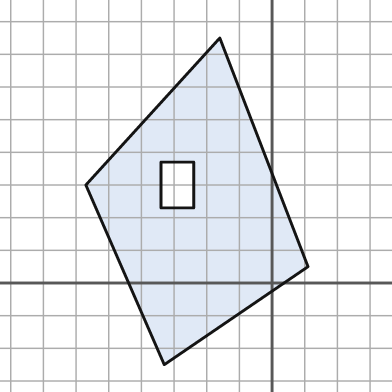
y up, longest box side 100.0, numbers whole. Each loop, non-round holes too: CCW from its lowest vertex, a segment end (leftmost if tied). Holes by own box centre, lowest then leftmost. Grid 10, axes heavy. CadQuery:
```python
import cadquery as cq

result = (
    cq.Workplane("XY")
    .moveTo(-33.0, -25.0)
    .lineTo(11.0, 5.0)
    .lineTo(-16.0, 75.0)
    .lineTo(-57.0, 30.0)
    .close()
    .moveTo(-34.0, 23.0)
    .lineTo(-24.0, 23.0)
    .lineTo(-24.0, 37.0)
    .lineTo(-34.0, 37.0)
    .close()
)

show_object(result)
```